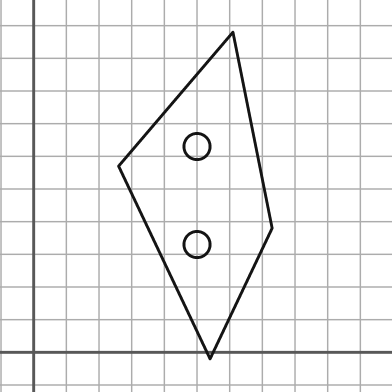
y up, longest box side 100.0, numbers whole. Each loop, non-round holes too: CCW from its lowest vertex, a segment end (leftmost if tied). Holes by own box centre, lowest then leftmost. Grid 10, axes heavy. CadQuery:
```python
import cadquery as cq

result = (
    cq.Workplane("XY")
    .moveTo(54.0, -2.0)
    .lineTo(73.0, 38.0)
    .lineTo(61.0, 98.0)
    .lineTo(26.0, 57.0)
    .close()
    .moveTo(50.0, 33.0)
    .circle(4.0)
    .moveTo(50.0, 63.0)
    .circle(4.0)
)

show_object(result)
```